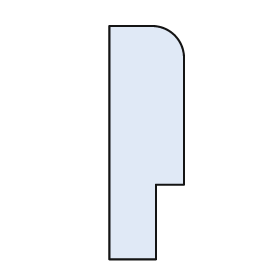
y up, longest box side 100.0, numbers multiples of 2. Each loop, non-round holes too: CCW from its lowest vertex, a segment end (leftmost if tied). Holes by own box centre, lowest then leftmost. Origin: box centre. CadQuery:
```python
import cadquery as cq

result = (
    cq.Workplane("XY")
    .moveTo(-16.0, -50.0)
    .lineTo(4.0, -50.0)
    .lineTo(4.0, -18.0)
    .lineTo(16.0, -18.0)
    .lineTo(16.0, 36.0)
    .threePointArc((12.0, 46.0), (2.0, 50.0))
    .lineTo(-16.0, 50.0)
    .close()
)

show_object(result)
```